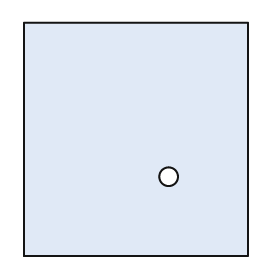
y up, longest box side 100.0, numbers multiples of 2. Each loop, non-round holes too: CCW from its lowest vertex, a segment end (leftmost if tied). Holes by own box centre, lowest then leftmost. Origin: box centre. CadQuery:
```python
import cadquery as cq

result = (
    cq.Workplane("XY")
    .moveTo(-48.0, -50.0)
    .lineTo(48.0, -50.0)
    .lineTo(48.0, 50.0)
    .lineTo(-48.0, 50.0)
    .close()
    .moveTo(14.0, -16.0)
    .circle(4.0)
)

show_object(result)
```